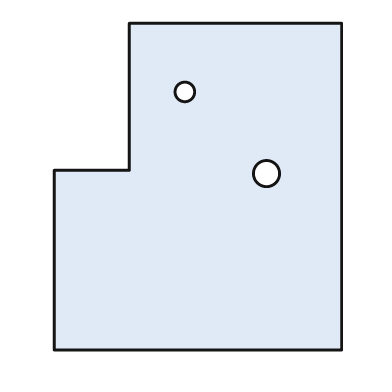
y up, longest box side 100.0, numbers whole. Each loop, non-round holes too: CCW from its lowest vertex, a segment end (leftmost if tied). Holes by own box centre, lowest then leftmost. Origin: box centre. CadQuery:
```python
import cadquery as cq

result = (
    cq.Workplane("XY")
    .moveTo(-44.0, -50.0)
    .lineTo(44.0, -50.0)
    .lineTo(44.0, 50.0)
    .lineTo(-21.0, 50.0)
    .lineTo(-21.0, 5.0)
    .lineTo(-44.0, 5.0)
    .close()
    .moveTo(21.0, 4.0)
    .circle(4.0)
    .moveTo(-4.0, 29.0)
    .circle(3.0)
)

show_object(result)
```